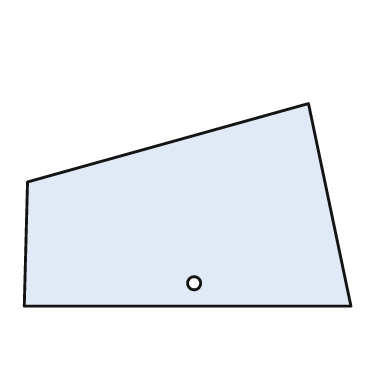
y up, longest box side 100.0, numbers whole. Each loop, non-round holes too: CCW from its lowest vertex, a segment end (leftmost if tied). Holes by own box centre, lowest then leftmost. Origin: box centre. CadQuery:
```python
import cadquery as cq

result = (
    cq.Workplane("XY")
    .moveTo(-50.0, -31.0)
    .lineTo(50.0, -31.0)
    .lineTo(37.0, 31.0)
    .lineTo(-49.0, 7.0)
    .close()
    .moveTo(2.0, -24.0)
    .circle(2.0)
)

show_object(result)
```